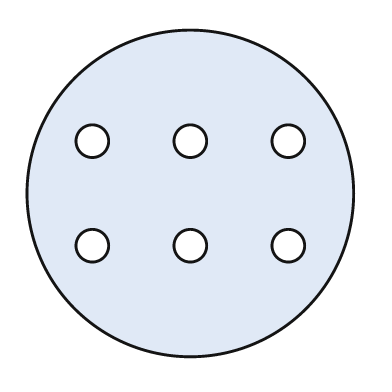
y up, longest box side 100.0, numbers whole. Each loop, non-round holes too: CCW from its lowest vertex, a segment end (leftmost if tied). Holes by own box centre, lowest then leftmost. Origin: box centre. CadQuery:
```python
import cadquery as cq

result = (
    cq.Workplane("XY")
    .moveTo(0.0, 0.0)
    .circle(50.0)
    .moveTo(-30.0, -16.0)
    .circle(5.0)
    .moveTo(0.0, -16.0)
    .circle(5.0)
    .moveTo(30.0, -16.0)
    .circle(5.0)
    .moveTo(-30.0, 16.0)
    .circle(5.0)
    .moveTo(0.0, 16.0)
    .circle(5.0)
    .moveTo(30.0, 16.0)
    .circle(5.0)
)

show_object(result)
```